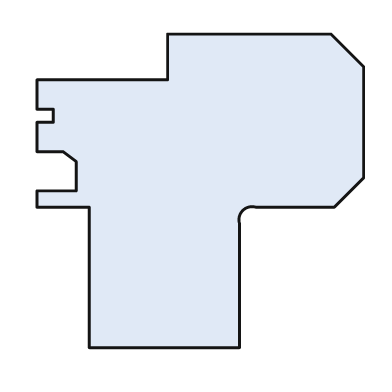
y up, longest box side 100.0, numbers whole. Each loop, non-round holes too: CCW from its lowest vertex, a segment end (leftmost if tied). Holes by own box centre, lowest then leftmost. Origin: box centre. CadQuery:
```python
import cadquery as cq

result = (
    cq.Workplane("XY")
    .moveTo(-34.0, -48.0)
    .lineTo(12.0, -48.0)
    .lineTo(12.0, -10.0)
    .threePointArc((13.0, -6.0), (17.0, -5.0))
    .lineTo(41.0, -5.0)
    .lineTo(50.0, 4.0)
    .lineTo(50.0, 38.0)
    .lineTo(40.0, 48.0)
    .lineTo(-10.0, 48.0)
    .lineTo(-10.0, 34.0)
    .lineTo(-50.0, 34.0)
    .lineTo(-50.0, 25.0)
    .lineTo(-45.0, 25.0)
    .lineTo(-45.0, 21.0)
    .lineTo(-50.0, 21.0)
    .lineTo(-50.0, 12.0)
    .lineTo(-42.0, 12.0)
    .lineTo(-38.0, 9.0)
    .lineTo(-38.0, 0.0)
    .lineTo(-50.0, 0.0)
    .lineTo(-50.0, -5.0)
    .lineTo(-34.0, -5.0)
    .close()
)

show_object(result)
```